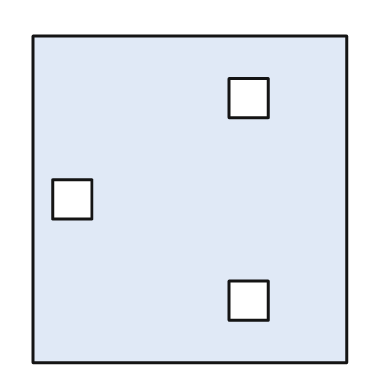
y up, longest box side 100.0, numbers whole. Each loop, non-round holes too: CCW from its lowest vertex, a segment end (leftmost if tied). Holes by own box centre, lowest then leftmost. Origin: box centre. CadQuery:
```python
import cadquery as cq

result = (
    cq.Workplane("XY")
    .moveTo(-48.0, -50.0)
    .lineTo(48.0, -50.0)
    .lineTo(48.0, 50.0)
    .lineTo(-48.0, 50.0)
    .close()
    .moveTo(12.0, -37.0)
    .lineTo(24.0, -37.0)
    .lineTo(24.0, -25.0)
    .lineTo(12.0, -25.0)
    .close()
    .moveTo(-42.0, -6.0)
    .lineTo(-30.0, -6.0)
    .lineTo(-30.0, 6.0)
    .lineTo(-42.0, 6.0)
    .close()
    .moveTo(12.0, 25.0)
    .lineTo(24.0, 25.0)
    .lineTo(24.0, 37.0)
    .lineTo(12.0, 37.0)
    .close()
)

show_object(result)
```